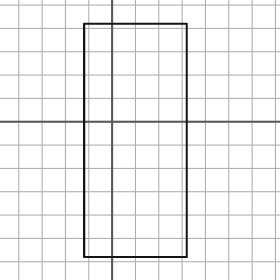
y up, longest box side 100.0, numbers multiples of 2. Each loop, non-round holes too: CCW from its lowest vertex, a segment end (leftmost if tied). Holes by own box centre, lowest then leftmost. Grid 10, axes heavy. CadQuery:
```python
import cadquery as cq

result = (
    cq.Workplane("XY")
    .moveTo(-12.0, -58.0)
    .lineTo(32.0, -58.0)
    .lineTo(32.0, 42.0)
    .lineTo(-12.0, 42.0)
    .close()
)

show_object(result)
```